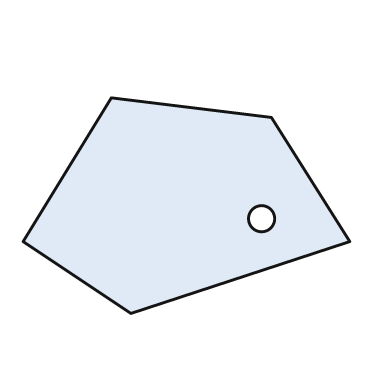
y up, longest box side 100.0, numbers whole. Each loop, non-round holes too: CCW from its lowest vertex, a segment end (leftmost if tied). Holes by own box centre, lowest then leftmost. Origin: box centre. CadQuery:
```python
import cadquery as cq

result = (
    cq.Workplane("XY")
    .moveTo(-17.0, -33.0)
    .lineTo(50.0, -11.0)
    .lineTo(26.0, 27.0)
    .lineTo(-23.0, 33.0)
    .lineTo(-50.0, -11.0)
    .close()
    .moveTo(23.0, -4.0)
    .circle(4.0)
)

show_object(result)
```